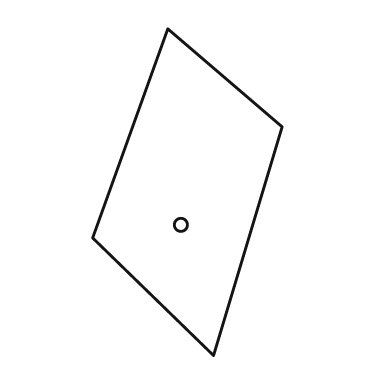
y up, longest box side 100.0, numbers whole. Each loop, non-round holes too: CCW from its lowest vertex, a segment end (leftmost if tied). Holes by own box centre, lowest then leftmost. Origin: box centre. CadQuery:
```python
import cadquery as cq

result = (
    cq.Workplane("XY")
    .moveTo(8.0, -50.0)
    .lineTo(29.0, 20.0)
    .lineTo(-6.0, 50.0)
    .lineTo(-29.0, -14.0)
    .close()
    .moveTo(-2.0, -10.0)
    .circle(2.0)
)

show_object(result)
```